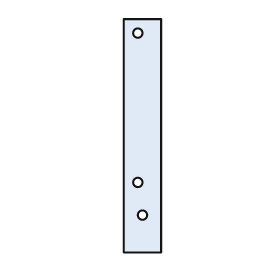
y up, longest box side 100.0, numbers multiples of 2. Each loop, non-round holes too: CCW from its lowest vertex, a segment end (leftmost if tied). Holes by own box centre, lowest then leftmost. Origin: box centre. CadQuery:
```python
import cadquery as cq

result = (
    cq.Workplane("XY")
    .moveTo(-8.0, -50.0)
    .lineTo(8.0, -50.0)
    .lineTo(8.0, 50.0)
    .lineTo(-8.0, 50.0)
    .close()
    .moveTo(0.0, -34.0)
    .circle(2.0)
    .moveTo(-2.0, -20.0)
    .circle(2.0)
    .moveTo(-2.0, 44.0)
    .circle(2.0)
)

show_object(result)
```